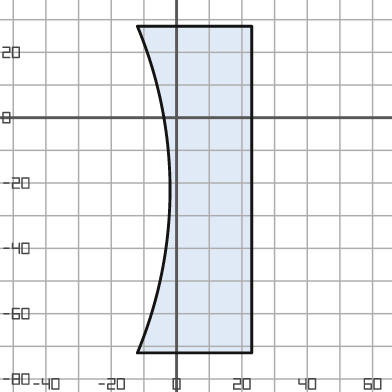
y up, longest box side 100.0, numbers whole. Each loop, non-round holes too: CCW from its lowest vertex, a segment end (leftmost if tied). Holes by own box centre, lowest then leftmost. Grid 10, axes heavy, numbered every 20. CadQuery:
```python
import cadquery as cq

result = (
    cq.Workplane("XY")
    .moveTo(-12.0, -72.0)
    .lineTo(23.0, -72.0)
    .lineTo(23.0, 28.0)
    .lineTo(-12.0, 28.0)
    .threePointArc((-2.0, -22.0), (-12.0, -72.0))
    .close()
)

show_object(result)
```